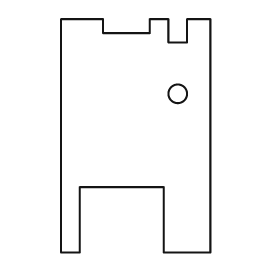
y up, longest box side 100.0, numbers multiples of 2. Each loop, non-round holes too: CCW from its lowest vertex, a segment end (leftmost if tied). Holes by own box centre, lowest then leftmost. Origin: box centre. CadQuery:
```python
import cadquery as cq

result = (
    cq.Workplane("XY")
    .moveTo(-32.0, -50.0)
    .lineTo(-24.0, -50.0)
    .lineTo(-24.0, -22.0)
    .lineTo(12.0, -22.0)
    .lineTo(12.0, -50.0)
    .lineTo(32.0, -50.0)
    .lineTo(32.0, 50.0)
    .lineTo(22.0, 50.0)
    .lineTo(22.0, 40.0)
    .lineTo(14.0, 40.0)
    .lineTo(14.0, 50.0)
    .lineTo(6.0, 50.0)
    .lineTo(6.0, 44.0)
    .lineTo(-14.0, 44.0)
    .lineTo(-14.0, 50.0)
    .lineTo(-32.0, 50.0)
    .close()
    .moveTo(18.0, 18.0)
    .circle(4.0)
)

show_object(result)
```